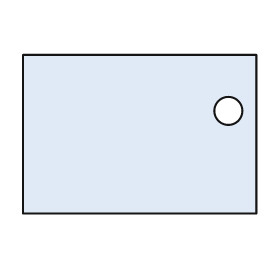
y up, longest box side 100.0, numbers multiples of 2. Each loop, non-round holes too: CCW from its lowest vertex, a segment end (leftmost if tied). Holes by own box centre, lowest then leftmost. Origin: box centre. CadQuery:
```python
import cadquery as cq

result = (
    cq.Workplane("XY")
    .moveTo(-50.0, -34.0)
    .lineTo(50.0, -34.0)
    .lineTo(50.0, 34.0)
    .lineTo(-50.0, 34.0)
    .close()
    .moveTo(38.0, 10.0)
    .circle(6.0)
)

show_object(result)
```